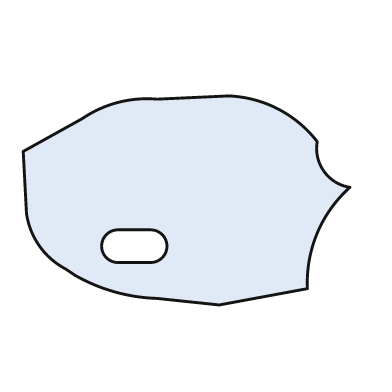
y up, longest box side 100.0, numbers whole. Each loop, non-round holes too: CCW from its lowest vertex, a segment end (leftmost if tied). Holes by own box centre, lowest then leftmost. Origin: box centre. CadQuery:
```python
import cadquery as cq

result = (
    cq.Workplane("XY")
    .moveTo(10.0, -32.0)
    .lineTo(37.0, -27.0)
    .threePointArc((40.0, -10.0), (50.0, 4.0))
    .threePointArc((42.0, 9.0), (40.0, 18.0))
    .threePointArc((28.0, 28.0), (13.0, 32.0))
    .lineTo(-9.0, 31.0)
    .threePointArc((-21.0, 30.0), (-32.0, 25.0))
    .lineTo(-50.0, 15.0)
    .lineTo(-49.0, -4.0)
    .threePointArc((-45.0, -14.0), (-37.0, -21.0))
    .lineTo(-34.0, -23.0)
    .threePointArc((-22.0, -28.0), (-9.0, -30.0))
    .close()
    .moveTo(-21.0, -19.0)
    .lineTo(-11.0, -19.0)
    .threePointArc((-6.0, -14.0), (-11.0, -9.0))
    .lineTo(-21.0, -9.0)
    .threePointArc((-26.0, -14.0), (-21.0, -19.0))
    .close()
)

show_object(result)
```